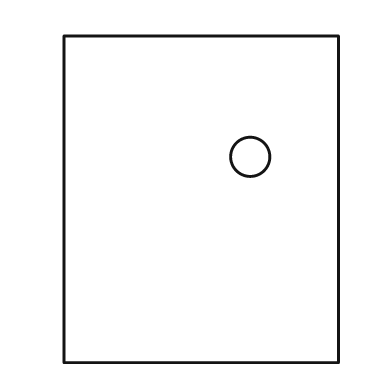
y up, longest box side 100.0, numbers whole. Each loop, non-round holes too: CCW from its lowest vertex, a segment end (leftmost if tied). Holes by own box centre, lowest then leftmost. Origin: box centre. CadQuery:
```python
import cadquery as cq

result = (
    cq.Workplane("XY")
    .moveTo(-42.0, -50.0)
    .lineTo(42.0, -50.0)
    .lineTo(42.0, 50.0)
    .lineTo(-42.0, 50.0)
    .close()
    .moveTo(15.0, 13.0)
    .circle(6.0)
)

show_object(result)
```